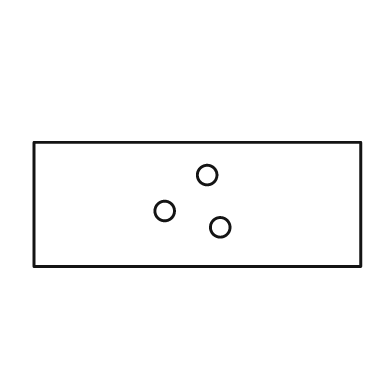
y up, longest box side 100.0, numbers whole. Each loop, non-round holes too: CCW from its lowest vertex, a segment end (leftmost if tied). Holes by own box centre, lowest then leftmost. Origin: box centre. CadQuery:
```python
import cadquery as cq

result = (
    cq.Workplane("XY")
    .moveTo(-50.0, -19.0)
    .lineTo(50.0, -19.0)
    .lineTo(50.0, 19.0)
    .lineTo(-50.0, 19.0)
    .close()
    .moveTo(7.0, -7.0)
    .circle(3.0)
    .moveTo(-10.0, -2.0)
    .circle(3.0)
    .moveTo(3.0, 9.0)
    .circle(3.0)
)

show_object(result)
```